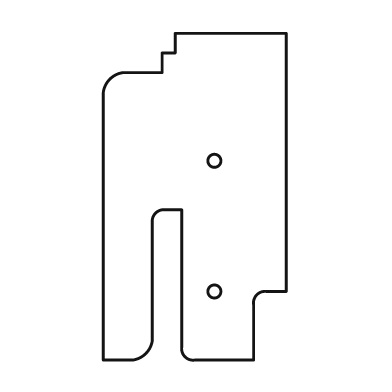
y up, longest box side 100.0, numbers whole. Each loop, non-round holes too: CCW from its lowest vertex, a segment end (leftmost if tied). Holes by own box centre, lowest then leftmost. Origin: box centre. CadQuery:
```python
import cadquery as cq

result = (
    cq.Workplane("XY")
    .moveTo(-28.0, -50.0)
    .lineTo(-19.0, -50.0)
    .threePointArc((-15.0, -48.0), (-13.0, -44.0))
    .lineTo(-13.0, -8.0)
    .threePointArc((-12.0, -5.0), (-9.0, -4.0))
    .lineTo(-4.0, -4.0)
    .lineTo(-4.0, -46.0)
    .threePointArc((-3.0, -49.0), (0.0, -50.0))
    .lineTo(18.0, -50.0)
    .lineTo(18.0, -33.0)
    .threePointArc((19.0, -30.0), (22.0, -29.0))
    .lineTo(28.0, -29.0)
    .lineTo(28.0, 50.0)
    .lineTo(-6.0, 50.0)
    .lineTo(-6.0, 44.0)
    .lineTo(-10.0, 44.0)
    .lineTo(-10.0, 38.0)
    .lineTo(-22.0, 38.0)
    .threePointArc((-26.0, 36.0), (-28.0, 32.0))
    .close()
    .moveTo(6.0, -29.0)
    .circle(2.0)
    .moveTo(6.0, 11.0)
    .circle(2.0)
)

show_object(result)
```